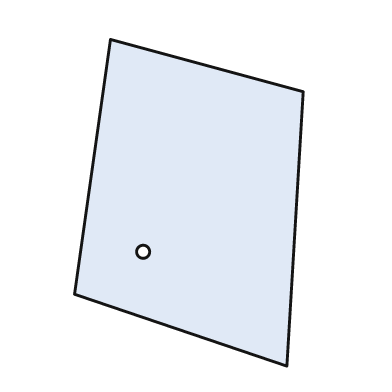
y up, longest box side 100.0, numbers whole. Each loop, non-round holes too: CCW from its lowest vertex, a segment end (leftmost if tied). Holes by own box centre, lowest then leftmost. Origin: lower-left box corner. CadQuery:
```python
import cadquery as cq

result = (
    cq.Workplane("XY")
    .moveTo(65.0, 0.0)
    .lineTo(70.0, 84.0)
    .lineTo(11.0, 100.0)
    .lineTo(0.0, 22.0)
    .close()
    .moveTo(21.0, 35.0)
    .circle(2.0)
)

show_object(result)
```